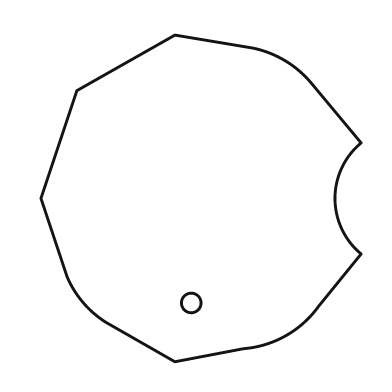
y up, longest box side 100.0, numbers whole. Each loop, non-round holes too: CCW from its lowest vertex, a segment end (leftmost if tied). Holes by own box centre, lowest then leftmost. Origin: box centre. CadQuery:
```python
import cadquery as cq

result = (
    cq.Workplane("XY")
    .moveTo(-8.0, -50.0)
    .lineTo(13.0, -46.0)
    .threePointArc((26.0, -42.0), (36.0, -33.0))
    .lineTo(49.0, -17.0)
    .threePointArc((41.0, 0.0), (49.0, 17.0))
    .lineTo(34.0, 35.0)
    .threePointArc((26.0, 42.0), (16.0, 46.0))
    .lineTo(-8.0, 50.0)
    .lineTo(-38.0, 33.0)
    .lineTo(-49.0, 0.0)
    .lineTo(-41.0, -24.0)
    .threePointArc((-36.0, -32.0), (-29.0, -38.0))
    .close()
    .moveTo(-3.0, -32.0)
    .circle(3.0)
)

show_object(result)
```